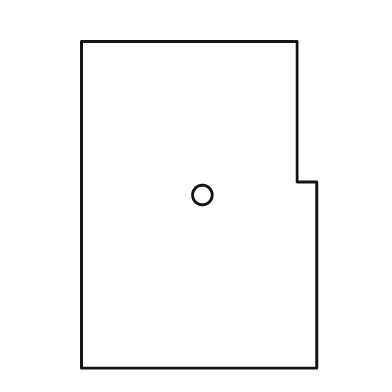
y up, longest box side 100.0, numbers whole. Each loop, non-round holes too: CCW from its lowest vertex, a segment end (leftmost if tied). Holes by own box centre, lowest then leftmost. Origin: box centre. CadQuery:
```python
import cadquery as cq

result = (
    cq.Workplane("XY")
    .moveTo(-36.0, -50.0)
    .lineTo(36.0, -50.0)
    .lineTo(36.0, 7.0)
    .lineTo(30.0, 7.0)
    .lineTo(30.0, 50.0)
    .lineTo(-36.0, 50.0)
    .close()
    .moveTo(1.0, 3.0)
    .circle(3.0)
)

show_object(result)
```